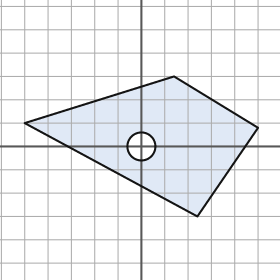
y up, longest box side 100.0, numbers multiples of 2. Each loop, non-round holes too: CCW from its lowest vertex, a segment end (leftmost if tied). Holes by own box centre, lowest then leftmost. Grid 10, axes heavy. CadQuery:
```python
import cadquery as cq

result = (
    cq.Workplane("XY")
    .moveTo(24.0, -30.0)
    .lineTo(50.0, 8.0)
    .lineTo(14.0, 30.0)
    .lineTo(-50.0, 10.0)
    .close()
    .moveTo(0.0, 0.0)
    .circle(6.0)
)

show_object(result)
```